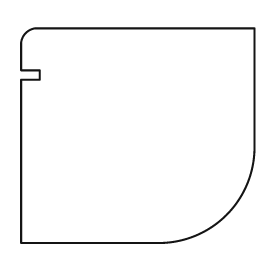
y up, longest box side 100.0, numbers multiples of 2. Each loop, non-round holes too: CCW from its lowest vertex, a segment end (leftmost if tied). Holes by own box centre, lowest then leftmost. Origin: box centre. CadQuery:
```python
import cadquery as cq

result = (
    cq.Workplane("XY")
    .moveTo(-50.0, -46.0)
    .lineTo(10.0, -46.0)
    .threePointArc((38.0, -34.0), (50.0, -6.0))
    .lineTo(50.0, 46.0)
    .lineTo(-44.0, 46.0)
    .threePointArc((-48.0, 44.0), (-50.0, 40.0))
    .lineTo(-50.0, 28.0)
    .lineTo(-42.0, 28.0)
    .lineTo(-42.0, 24.0)
    .lineTo(-50.0, 24.0)
    .close()
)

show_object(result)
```